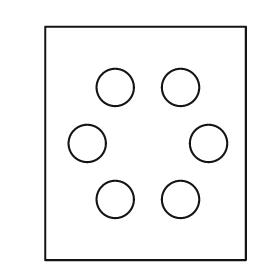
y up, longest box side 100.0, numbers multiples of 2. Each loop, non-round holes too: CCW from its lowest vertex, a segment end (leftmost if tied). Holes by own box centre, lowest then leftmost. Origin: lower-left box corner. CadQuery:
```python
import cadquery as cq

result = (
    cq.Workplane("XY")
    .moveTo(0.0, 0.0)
    .lineTo(86.0, 0.0)
    .lineTo(86.0, 100.0)
    .lineTo(0.0, 100.0)
    .close()
    .moveTo(30.0, 26.0)
    .circle(8.0)
    .moveTo(58.0, 26.0)
    .circle(8.0)
    .moveTo(18.0, 50.0)
    .circle(8.0)
    .moveTo(70.0, 50.0)
    .circle(8.0)
    .moveTo(30.0, 74.0)
    .circle(8.0)
    .moveTo(58.0, 74.0)
    .circle(8.0)
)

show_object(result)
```